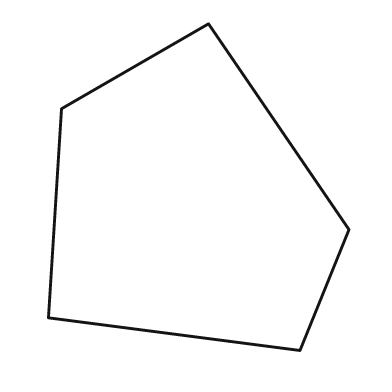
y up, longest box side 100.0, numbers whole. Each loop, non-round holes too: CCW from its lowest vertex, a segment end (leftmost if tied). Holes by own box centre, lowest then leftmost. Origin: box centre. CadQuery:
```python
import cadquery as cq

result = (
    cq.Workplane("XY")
    .moveTo(31.0, -50.0)
    .lineTo(46.0, -13.0)
    .lineTo(3.0, 50.0)
    .lineTo(-42.0, 24.0)
    .lineTo(-46.0, -40.0)
    .close()
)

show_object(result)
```